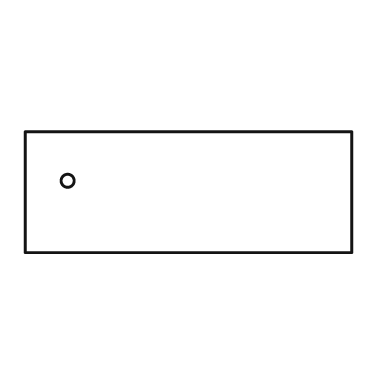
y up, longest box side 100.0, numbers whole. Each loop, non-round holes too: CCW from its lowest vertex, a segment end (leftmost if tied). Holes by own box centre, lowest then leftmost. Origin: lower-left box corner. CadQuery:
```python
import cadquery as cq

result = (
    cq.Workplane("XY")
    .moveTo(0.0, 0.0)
    .lineTo(100.0, 0.0)
    .lineTo(100.0, 37.0)
    .lineTo(0.0, 37.0)
    .close()
    .moveTo(13.0, 22.0)
    .circle(2.0)
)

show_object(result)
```